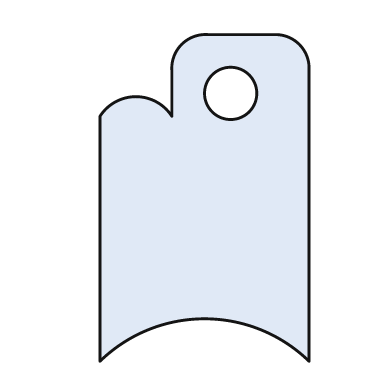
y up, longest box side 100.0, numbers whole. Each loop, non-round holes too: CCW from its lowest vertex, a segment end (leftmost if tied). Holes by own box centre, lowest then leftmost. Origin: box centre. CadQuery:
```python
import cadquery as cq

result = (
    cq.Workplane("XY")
    .moveTo(-32.0, -50.0)
    .threePointArc((0.0, -37.0), (32.0, -50.0))
    .lineTo(32.0, 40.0)
    .threePointArc((29.0, 47.0), (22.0, 50.0))
    .lineTo(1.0, 50.0)
    .threePointArc((-7.0, 47.0), (-10.0, 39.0))
    .lineTo(-10.0, 25.0)
    .threePointArc((-21.0, 31.0), (-32.0, 25.0))
    .close()
    .moveTo(8.0, 32.0)
    .circle(8.0)
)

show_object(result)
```